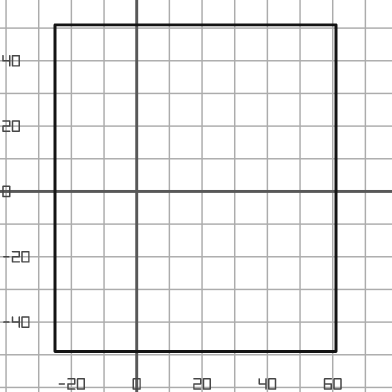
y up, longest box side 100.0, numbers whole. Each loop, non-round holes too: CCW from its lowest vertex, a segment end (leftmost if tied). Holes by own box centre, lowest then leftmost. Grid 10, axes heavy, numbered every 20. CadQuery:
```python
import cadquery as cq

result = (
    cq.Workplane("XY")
    .moveTo(-25.0, -49.0)
    .lineTo(61.0, -49.0)
    .lineTo(61.0, 51.0)
    .lineTo(-25.0, 51.0)
    .close()
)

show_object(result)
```